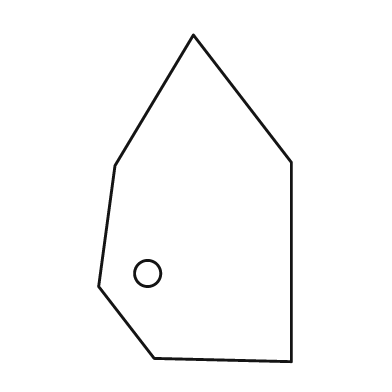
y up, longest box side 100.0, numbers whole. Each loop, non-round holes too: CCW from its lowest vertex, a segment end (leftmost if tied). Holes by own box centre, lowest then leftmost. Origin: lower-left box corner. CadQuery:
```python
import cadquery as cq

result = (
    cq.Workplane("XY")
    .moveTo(59.0, 0.0)
    .lineTo(59.0, 61.0)
    .lineTo(29.0, 100.0)
    .lineTo(5.0, 60.0)
    .lineTo(0.0, 23.0)
    .lineTo(17.0, 1.0)
    .close()
    .moveTo(15.0, 27.0)
    .circle(4.0)
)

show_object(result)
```